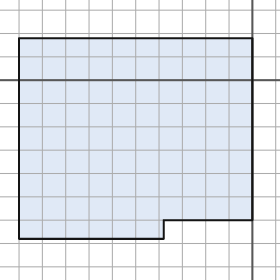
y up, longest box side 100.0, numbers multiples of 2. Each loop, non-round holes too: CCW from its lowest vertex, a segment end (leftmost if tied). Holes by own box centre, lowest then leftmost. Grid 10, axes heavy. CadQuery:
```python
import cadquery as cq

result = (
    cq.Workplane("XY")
    .moveTo(-100.0, -68.0)
    .lineTo(-38.0, -68.0)
    .lineTo(-38.0, -60.0)
    .lineTo(0.0, -60.0)
    .lineTo(0.0, 18.0)
    .lineTo(-100.0, 18.0)
    .close()
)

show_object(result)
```